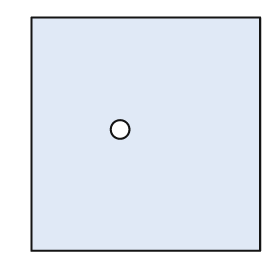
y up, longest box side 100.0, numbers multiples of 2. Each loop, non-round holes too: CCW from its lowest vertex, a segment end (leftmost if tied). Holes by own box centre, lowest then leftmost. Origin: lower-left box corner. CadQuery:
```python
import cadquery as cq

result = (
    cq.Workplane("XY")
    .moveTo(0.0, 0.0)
    .lineTo(98.0, 0.0)
    .lineTo(98.0, 100.0)
    .lineTo(0.0, 100.0)
    .close()
    .moveTo(38.0, 52.0)
    .circle(4.0)
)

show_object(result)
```